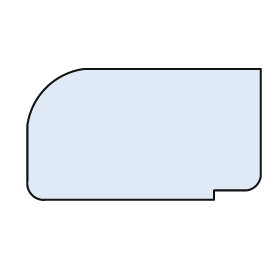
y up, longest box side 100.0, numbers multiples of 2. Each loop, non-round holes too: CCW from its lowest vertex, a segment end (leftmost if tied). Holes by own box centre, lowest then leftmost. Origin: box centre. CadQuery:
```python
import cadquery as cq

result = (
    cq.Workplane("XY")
    .moveTo(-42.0, -28.0)
    .lineTo(30.0, -28.0)
    .lineTo(30.0, -24.0)
    .lineTo(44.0, -24.0)
    .threePointArc((48.0, -22.0), (50.0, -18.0))
    .lineTo(50.0, 28.0)
    .lineTo(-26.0, 28.0)
    .threePointArc((-42.0, 20.0), (-50.0, 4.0))
    .lineTo(-50.0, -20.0)
    .threePointArc((-48.0, -26.0), (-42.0, -28.0))
    .close()
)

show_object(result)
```